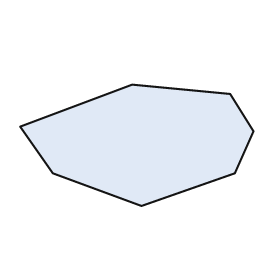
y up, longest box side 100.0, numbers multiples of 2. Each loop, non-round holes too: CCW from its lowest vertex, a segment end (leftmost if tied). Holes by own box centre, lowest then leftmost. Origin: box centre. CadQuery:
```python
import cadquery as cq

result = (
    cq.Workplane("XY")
    .moveTo(2.0, -26.0)
    .lineTo(42.0, -12.0)
    .lineTo(50.0, 6.0)
    .lineTo(40.0, 22.0)
    .lineTo(-2.0, 26.0)
    .lineTo(-50.0, 8.0)
    .lineTo(-36.0, -12.0)
    .close()
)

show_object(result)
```